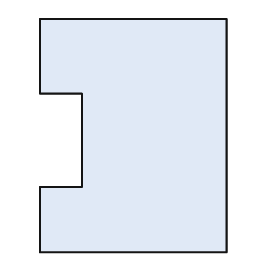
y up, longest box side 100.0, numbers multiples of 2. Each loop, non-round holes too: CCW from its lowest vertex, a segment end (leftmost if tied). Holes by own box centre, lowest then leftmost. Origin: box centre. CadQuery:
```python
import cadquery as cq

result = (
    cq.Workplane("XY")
    .moveTo(-40.0, -50.0)
    .lineTo(40.0, -50.0)
    .lineTo(40.0, 50.0)
    .lineTo(-40.0, 50.0)
    .lineTo(-40.0, 18.0)
    .lineTo(-22.0, 18.0)
    .lineTo(-22.0, -22.0)
    .lineTo(-40.0, -22.0)
    .close()
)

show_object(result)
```